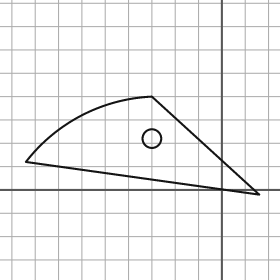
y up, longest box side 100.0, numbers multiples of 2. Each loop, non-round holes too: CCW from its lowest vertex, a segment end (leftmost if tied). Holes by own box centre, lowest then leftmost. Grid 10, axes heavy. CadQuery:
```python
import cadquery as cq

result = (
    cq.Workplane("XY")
    .moveTo(16.0, -2.0)
    .lineTo(-30.0, 40.0)
    .threePointArc((-60.0, 32.0), (-84.0, 12.0))
    .close()
    .moveTo(-30.0, 22.0)
    .circle(4.0)
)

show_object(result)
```